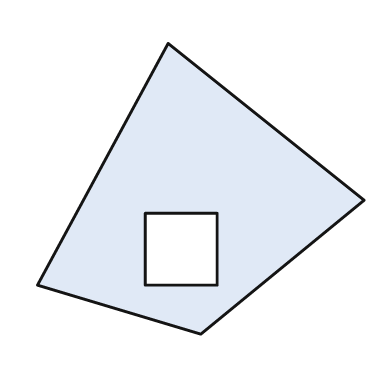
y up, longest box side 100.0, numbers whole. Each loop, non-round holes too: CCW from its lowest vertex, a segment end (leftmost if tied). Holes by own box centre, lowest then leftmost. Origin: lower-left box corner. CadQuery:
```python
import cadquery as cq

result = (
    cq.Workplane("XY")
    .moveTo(50.0, 0.0)
    .lineTo(100.0, 41.0)
    .lineTo(40.0, 89.0)
    .lineTo(0.0, 15.0)
    .close()
    .moveTo(33.0, 15.0)
    .lineTo(55.0, 15.0)
    .lineTo(55.0, 37.0)
    .lineTo(33.0, 37.0)
    .close()
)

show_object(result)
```